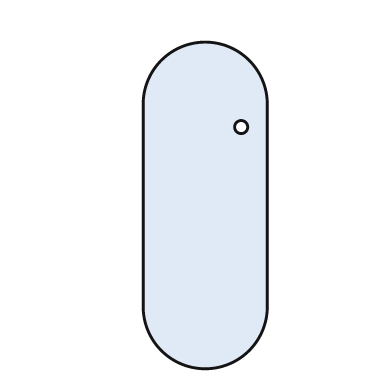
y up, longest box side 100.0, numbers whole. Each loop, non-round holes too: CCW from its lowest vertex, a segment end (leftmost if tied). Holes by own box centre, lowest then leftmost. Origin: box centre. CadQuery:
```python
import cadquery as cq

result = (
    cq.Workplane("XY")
    .moveTo(-19.0, -31.0)
    .threePointArc((0.0, -50.0), (19.0, -31.0))
    .lineTo(19.0, 31.0)
    .threePointArc((0.0, 50.0), (-19.0, 31.0))
    .close()
    .moveTo(11.0, 24.0)
    .circle(2.0)
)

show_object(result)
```